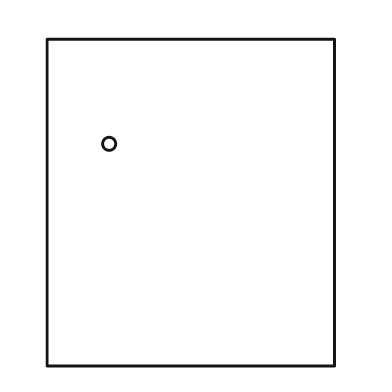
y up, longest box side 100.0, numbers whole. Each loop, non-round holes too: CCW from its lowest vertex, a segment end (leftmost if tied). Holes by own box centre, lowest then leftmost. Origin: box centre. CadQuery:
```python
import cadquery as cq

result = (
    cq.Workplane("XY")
    .moveTo(-44.0, -50.0)
    .lineTo(44.0, -50.0)
    .lineTo(44.0, 50.0)
    .lineTo(-44.0, 50.0)
    .close()
    .moveTo(-25.0, 18.0)
    .circle(2.0)
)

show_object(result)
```